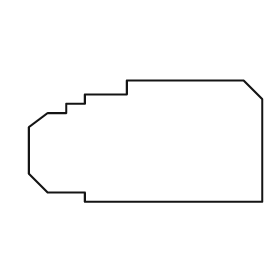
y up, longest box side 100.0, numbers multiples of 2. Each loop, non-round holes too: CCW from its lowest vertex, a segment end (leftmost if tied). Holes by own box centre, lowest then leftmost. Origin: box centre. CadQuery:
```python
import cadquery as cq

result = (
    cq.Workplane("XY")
    .moveTo(-26.0, -26.0)
    .lineTo(50.0, -26.0)
    .lineTo(50.0, 18.0)
    .lineTo(42.0, 26.0)
    .lineTo(-8.0, 26.0)
    .lineTo(-8.0, 20.0)
    .lineTo(-26.0, 20.0)
    .lineTo(-26.0, 16.0)
    .lineTo(-34.0, 16.0)
    .lineTo(-34.0, 12.0)
    .lineTo(-42.0, 12.0)
    .lineTo(-50.0, 6.0)
    .lineTo(-50.0, -14.0)
    .lineTo(-42.0, -22.0)
    .lineTo(-26.0, -22.0)
    .close()
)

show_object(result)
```